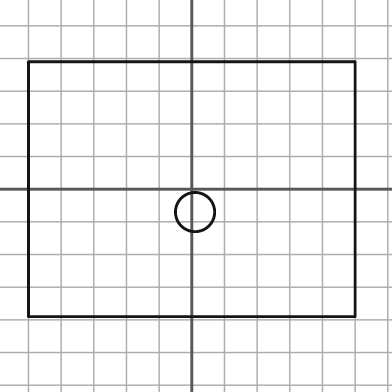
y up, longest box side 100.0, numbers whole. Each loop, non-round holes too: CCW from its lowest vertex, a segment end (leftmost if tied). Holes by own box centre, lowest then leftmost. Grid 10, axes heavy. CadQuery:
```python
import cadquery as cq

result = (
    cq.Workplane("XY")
    .moveTo(-50.0, -39.0)
    .lineTo(50.0, -39.0)
    .lineTo(50.0, 39.0)
    .lineTo(-50.0, 39.0)
    .close()
    .moveTo(1.0, -7.0)
    .circle(6.0)
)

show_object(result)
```